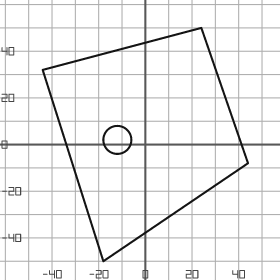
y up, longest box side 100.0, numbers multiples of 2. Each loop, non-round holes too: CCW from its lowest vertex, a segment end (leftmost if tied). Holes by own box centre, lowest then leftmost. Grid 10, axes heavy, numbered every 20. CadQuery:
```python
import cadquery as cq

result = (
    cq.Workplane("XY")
    .moveTo(-18.0, -50.0)
    .lineTo(44.0, -8.0)
    .lineTo(24.0, 50.0)
    .lineTo(-44.0, 32.0)
    .close()
    .moveTo(-12.0, 2.0)
    .circle(6.0)
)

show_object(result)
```